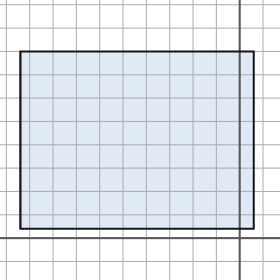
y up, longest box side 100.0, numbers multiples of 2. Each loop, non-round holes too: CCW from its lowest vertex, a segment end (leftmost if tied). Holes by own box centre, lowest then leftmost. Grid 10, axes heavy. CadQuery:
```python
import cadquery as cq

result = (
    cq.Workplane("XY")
    .moveTo(-94.0, 4.0)
    .lineTo(6.0, 4.0)
    .lineTo(6.0, 80.0)
    .lineTo(-94.0, 80.0)
    .close()
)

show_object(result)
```